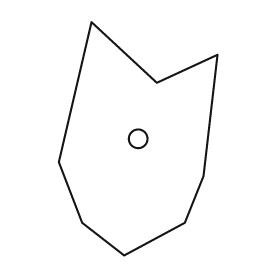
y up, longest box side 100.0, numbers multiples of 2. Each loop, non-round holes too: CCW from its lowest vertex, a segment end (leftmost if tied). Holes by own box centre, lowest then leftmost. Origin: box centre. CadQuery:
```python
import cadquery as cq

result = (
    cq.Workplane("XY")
    .moveTo(-6.0, -50.0)
    .lineTo(20.0, -36.0)
    .lineTo(28.0, -16.0)
    .lineTo(34.0, 36.0)
    .lineTo(8.0, 24.0)
    .lineTo(-20.0, 50.0)
    .lineTo(-34.0, -10.0)
    .lineTo(-24.0, -36.0)
    .close()
    .moveTo(0.0, 0.0)
    .circle(4.0)
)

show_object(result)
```